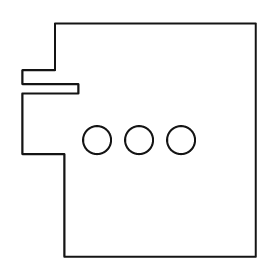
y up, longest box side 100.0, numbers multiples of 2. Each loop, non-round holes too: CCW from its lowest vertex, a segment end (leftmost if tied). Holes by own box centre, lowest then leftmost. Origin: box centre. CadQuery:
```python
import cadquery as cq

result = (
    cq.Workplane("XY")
    .moveTo(-32.0, -50.0)
    .lineTo(50.0, -50.0)
    .lineTo(50.0, 50.0)
    .lineTo(-36.0, 50.0)
    .lineTo(-36.0, 30.0)
    .lineTo(-50.0, 30.0)
    .lineTo(-50.0, 24.0)
    .lineTo(-26.0, 24.0)
    .lineTo(-26.0, 20.0)
    .lineTo(-50.0, 20.0)
    .lineTo(-50.0, -6.0)
    .lineTo(-32.0, -6.0)
    .close()
    .moveTo(-18.0, 0.0)
    .circle(6.0)
    .moveTo(0.0, 0.0)
    .circle(6.0)
    .moveTo(18.0, 0.0)
    .circle(6.0)
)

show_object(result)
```